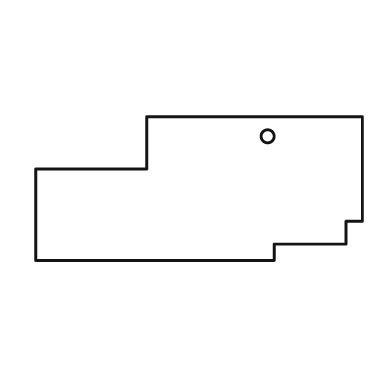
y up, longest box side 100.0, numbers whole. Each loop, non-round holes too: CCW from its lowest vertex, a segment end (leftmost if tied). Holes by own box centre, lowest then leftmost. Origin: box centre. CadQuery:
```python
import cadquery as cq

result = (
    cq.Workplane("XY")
    .moveTo(-50.0, -22.0)
    .lineTo(23.0, -22.0)
    .lineTo(23.0, -17.0)
    .lineTo(45.0, -17.0)
    .lineTo(45.0, -10.0)
    .lineTo(50.0, -10.0)
    .lineTo(50.0, 22.0)
    .lineTo(-16.0, 22.0)
    .lineTo(-16.0, 6.0)
    .lineTo(-50.0, 6.0)
    .close()
    .moveTo(21.0, 16.0)
    .circle(2.0)
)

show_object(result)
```